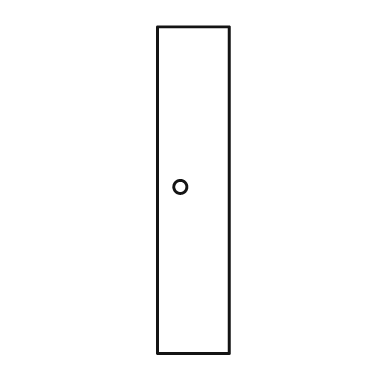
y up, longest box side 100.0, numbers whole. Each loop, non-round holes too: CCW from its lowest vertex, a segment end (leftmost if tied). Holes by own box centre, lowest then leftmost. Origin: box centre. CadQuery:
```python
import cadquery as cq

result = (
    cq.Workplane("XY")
    .moveTo(-11.0, -50.0)
    .lineTo(11.0, -50.0)
    .lineTo(11.0, 50.0)
    .lineTo(-11.0, 50.0)
    .close()
    .moveTo(-4.0, 1.0)
    .circle(2.0)
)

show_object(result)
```